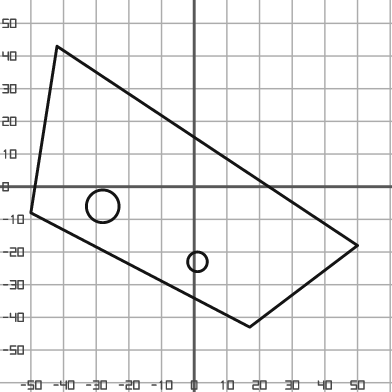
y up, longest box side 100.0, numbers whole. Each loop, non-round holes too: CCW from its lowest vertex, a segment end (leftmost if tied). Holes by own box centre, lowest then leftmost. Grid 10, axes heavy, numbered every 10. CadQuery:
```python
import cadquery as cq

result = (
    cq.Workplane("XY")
    .moveTo(17.0, -43.0)
    .lineTo(50.0, -18.0)
    .lineTo(-42.0, 43.0)
    .lineTo(-50.0, -8.0)
    .close()
    .moveTo(1.0, -23.0)
    .circle(3.0)
    .moveTo(-28.0, -6.0)
    .circle(5.0)
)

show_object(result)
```